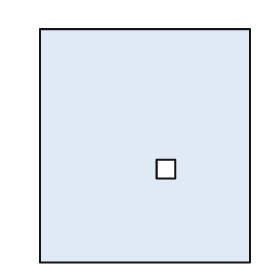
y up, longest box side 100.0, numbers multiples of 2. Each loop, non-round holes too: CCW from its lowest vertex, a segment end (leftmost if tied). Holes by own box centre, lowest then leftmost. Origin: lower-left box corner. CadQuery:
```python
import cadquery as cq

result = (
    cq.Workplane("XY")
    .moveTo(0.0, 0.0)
    .lineTo(90.0, 0.0)
    .lineTo(90.0, 100.0)
    .lineTo(0.0, 100.0)
    .close()
    .moveTo(50.0, 36.0)
    .lineTo(58.0, 36.0)
    .lineTo(58.0, 44.0)
    .lineTo(50.0, 44.0)
    .close()
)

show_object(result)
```